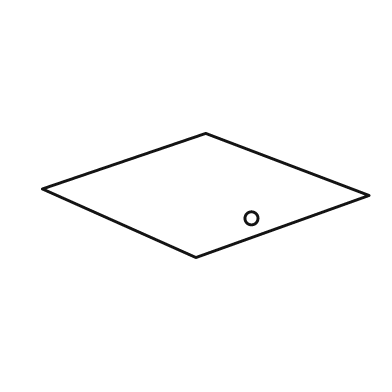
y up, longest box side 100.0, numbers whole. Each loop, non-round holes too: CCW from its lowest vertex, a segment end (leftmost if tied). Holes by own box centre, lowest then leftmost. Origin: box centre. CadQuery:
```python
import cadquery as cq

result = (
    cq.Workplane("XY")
    .moveTo(-3.0, -19.0)
    .lineTo(50.0, 0.0)
    .lineTo(0.0, 19.0)
    .lineTo(-50.0, 2.0)
    .close()
    .moveTo(14.0, -7.0)
    .circle(2.0)
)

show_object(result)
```